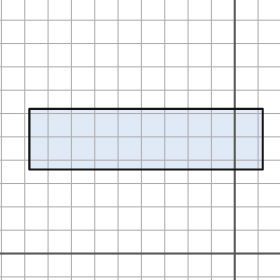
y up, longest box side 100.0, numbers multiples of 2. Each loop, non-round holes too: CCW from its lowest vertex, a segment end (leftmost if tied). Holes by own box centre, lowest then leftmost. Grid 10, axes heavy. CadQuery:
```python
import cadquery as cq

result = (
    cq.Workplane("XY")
    .moveTo(-88.0, 36.0)
    .lineTo(12.0, 36.0)
    .lineTo(12.0, 62.0)
    .lineTo(-88.0, 62.0)
    .close()
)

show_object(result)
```